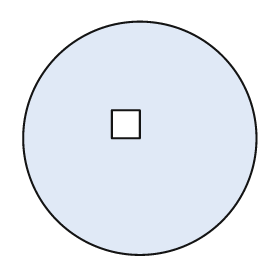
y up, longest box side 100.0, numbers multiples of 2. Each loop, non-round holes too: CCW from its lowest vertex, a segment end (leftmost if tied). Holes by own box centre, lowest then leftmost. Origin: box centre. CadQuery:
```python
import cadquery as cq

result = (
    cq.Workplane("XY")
    .moveTo(0.0, 0.0)
    .circle(50.0)
    .moveTo(-12.0, 0.0)
    .lineTo(0.0, 0.0)
    .lineTo(0.0, 12.0)
    .lineTo(-12.0, 12.0)
    .close()
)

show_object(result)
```